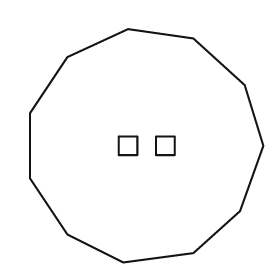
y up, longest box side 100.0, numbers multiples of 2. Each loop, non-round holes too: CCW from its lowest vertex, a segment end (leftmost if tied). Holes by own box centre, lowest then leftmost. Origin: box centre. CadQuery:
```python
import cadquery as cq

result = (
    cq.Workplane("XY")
    .moveTo(-10.0, -50.0)
    .lineTo(20.0, -46.0)
    .lineTo(40.0, -28.0)
    .lineTo(50.0, 0.0)
    .lineTo(42.0, 26.0)
    .lineTo(20.0, 46.0)
    .lineTo(-8.0, 50.0)
    .lineTo(-34.0, 38.0)
    .lineTo(-50.0, 14.0)
    .lineTo(-50.0, -14.0)
    .lineTo(-34.0, -38.0)
    .close()
    .moveTo(-12.0, -4.0)
    .lineTo(-4.0, -4.0)
    .lineTo(-4.0, 4.0)
    .lineTo(-12.0, 4.0)
    .close()
    .moveTo(4.0, -4.0)
    .lineTo(12.0, -4.0)
    .lineTo(12.0, 4.0)
    .lineTo(4.0, 4.0)
    .close()
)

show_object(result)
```